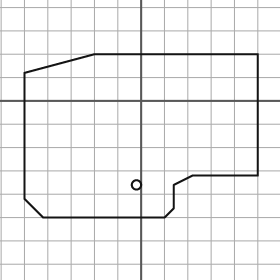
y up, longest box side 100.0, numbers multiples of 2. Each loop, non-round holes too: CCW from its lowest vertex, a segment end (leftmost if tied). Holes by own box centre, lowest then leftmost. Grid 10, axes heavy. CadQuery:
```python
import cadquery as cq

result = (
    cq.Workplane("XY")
    .moveTo(-42.0, -50.0)
    .lineTo(10.0, -50.0)
    .lineTo(14.0, -46.0)
    .lineTo(14.0, -36.0)
    .lineTo(22.0, -32.0)
    .lineTo(50.0, -32.0)
    .lineTo(50.0, 20.0)
    .lineTo(-20.0, 20.0)
    .lineTo(-50.0, 12.0)
    .lineTo(-50.0, -42.0)
    .close()
    .moveTo(-2.0, -36.0)
    .circle(2.0)
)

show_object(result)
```